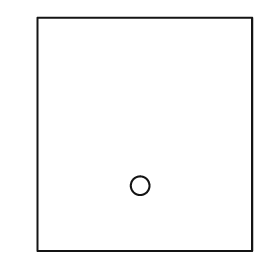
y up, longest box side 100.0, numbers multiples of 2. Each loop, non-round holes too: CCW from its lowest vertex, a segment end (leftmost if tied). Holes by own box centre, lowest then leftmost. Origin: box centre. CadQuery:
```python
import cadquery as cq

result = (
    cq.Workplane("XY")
    .moveTo(-46.0, -50.0)
    .lineTo(46.0, -50.0)
    .lineTo(46.0, 50.0)
    .lineTo(-46.0, 50.0)
    .close()
    .moveTo(-2.0, -22.0)
    .circle(4.0)
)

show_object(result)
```